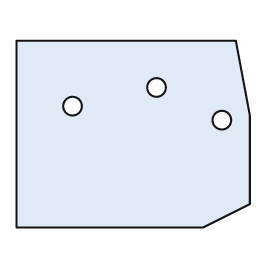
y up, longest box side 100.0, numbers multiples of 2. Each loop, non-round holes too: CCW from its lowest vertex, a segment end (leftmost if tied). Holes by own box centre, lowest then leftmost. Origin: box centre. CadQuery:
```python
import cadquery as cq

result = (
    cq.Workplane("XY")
    .moveTo(-50.0, -40.0)
    .lineTo(30.0, -40.0)
    .lineTo(50.0, -30.0)
    .lineTo(50.0, 8.0)
    .lineTo(44.0, 40.0)
    .lineTo(-50.0, 40.0)
    .close()
    .moveTo(38.0, 6.0)
    .circle(4.0)
    .moveTo(-26.0, 12.0)
    .circle(4.0)
    .moveTo(10.0, 20.0)
    .circle(4.0)
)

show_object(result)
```